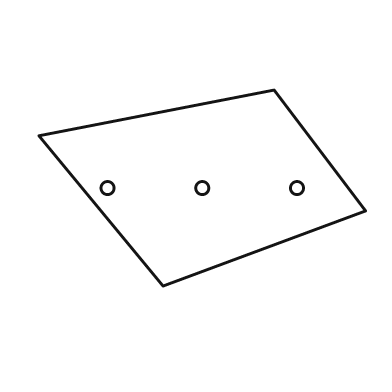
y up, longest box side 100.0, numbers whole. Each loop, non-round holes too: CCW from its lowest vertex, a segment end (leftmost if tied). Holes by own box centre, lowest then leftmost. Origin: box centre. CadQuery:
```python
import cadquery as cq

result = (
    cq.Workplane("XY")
    .moveTo(-12.0, -30.0)
    .lineTo(50.0, -7.0)
    .lineTo(22.0, 30.0)
    .lineTo(-50.0, 16.0)
    .close()
    .moveTo(-29.0, 0.0)
    .circle(2.0)
    .moveTo(0.0, 0.0)
    .circle(2.0)
    .moveTo(29.0, 0.0)
    .circle(2.0)
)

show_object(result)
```